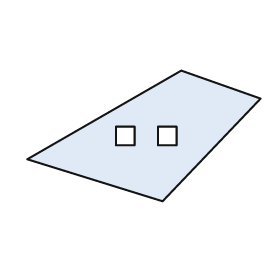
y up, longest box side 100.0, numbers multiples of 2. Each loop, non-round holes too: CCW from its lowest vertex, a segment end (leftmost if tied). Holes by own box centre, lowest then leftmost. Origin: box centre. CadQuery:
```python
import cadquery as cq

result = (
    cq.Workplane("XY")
    .moveTo(8.0, -28.0)
    .lineTo(50.0, 16.0)
    .lineTo(16.0, 28.0)
    .lineTo(-50.0, -10.0)
    .close()
    .moveTo(-12.0, -4.0)
    .lineTo(-4.0, -4.0)
    .lineTo(-4.0, 4.0)
    .lineTo(-12.0, 4.0)
    .close()
    .moveTo(6.0, -4.0)
    .lineTo(14.0, -4.0)
    .lineTo(14.0, 4.0)
    .lineTo(6.0, 4.0)
    .close()
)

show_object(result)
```